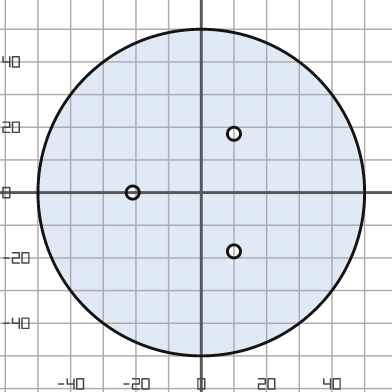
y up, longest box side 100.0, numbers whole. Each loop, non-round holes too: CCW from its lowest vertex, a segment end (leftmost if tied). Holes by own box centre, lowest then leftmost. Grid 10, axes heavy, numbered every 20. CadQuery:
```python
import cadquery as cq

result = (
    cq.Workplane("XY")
    .moveTo(0.0, 0.0)
    .circle(50.0)
    .moveTo(10.0, -18.0)
    .circle(2.0)
    .moveTo(-21.0, 0.0)
    .circle(2.0)
    .moveTo(10.0, 18.0)
    .circle(2.0)
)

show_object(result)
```